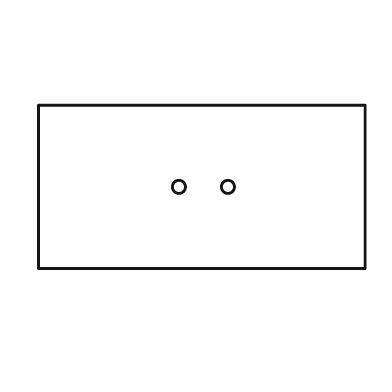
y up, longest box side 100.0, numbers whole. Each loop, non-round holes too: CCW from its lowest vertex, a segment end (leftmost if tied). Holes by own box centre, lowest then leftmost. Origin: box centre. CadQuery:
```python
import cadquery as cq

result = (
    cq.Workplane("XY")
    .moveTo(-50.0, -25.0)
    .lineTo(50.0, -25.0)
    .lineTo(50.0, 25.0)
    .lineTo(-50.0, 25.0)
    .close()
    .moveTo(-7.0, 0.0)
    .circle(2.0)
    .moveTo(8.0, 0.0)
    .circle(2.0)
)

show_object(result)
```